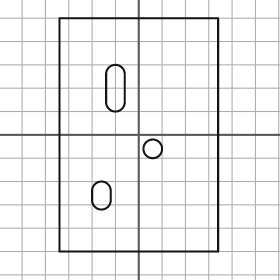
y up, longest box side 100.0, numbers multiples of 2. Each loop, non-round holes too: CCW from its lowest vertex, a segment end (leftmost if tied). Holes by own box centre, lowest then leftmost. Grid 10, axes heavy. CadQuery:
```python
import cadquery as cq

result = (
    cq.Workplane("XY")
    .moveTo(-34.0, -50.0)
    .lineTo(34.0, -50.0)
    .lineTo(34.0, 50.0)
    .lineTo(-34.0, 50.0)
    .close()
    .moveTo(-20.0, -28.0)
    .threePointArc((-16.0, -32.0), (-12.0, -28.0))
    .lineTo(-12.0, -24.0)
    .threePointArc((-16.0, -20.0), (-20.0, -24.0))
    .close()
    .moveTo(6.0, -6.0)
    .circle(4.0)
    .moveTo(-14.0, 14.0)
    .threePointArc((-10.0, 10.0), (-6.0, 14.0))
    .lineTo(-6.0, 26.0)
    .threePointArc((-10.0, 30.0), (-14.0, 26.0))
    .close()
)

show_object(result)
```